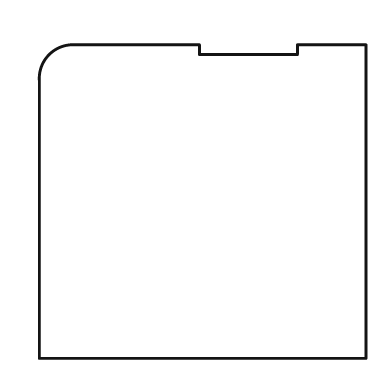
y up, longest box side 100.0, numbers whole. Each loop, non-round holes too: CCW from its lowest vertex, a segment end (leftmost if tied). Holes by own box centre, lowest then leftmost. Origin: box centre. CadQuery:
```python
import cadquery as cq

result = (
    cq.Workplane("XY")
    .moveTo(-50.0, -48.0)
    .lineTo(50.0, -48.0)
    .lineTo(50.0, 48.0)
    .lineTo(29.0, 48.0)
    .lineTo(29.0, 45.0)
    .lineTo(-1.0, 45.0)
    .lineTo(-1.0, 48.0)
    .lineTo(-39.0, 48.0)
    .threePointArc((-47.0, 45.0), (-50.0, 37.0))
    .close()
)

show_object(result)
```